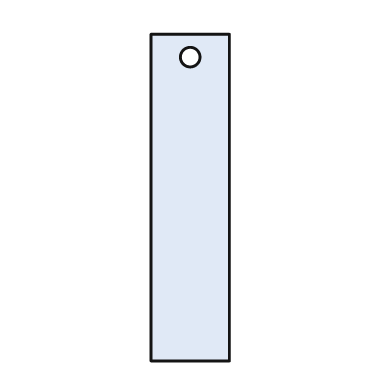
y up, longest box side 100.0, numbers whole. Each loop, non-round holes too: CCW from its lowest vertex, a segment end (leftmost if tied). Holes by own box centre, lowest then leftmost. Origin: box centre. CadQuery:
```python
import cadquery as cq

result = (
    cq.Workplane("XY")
    .moveTo(-12.0, -50.0)
    .lineTo(12.0, -50.0)
    .lineTo(12.0, 50.0)
    .lineTo(-12.0, 50.0)
    .close()
    .moveTo(0.0, 43.0)
    .circle(3.0)
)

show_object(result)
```